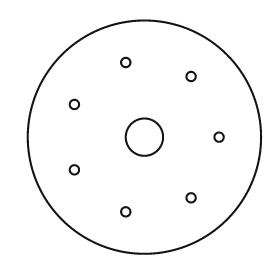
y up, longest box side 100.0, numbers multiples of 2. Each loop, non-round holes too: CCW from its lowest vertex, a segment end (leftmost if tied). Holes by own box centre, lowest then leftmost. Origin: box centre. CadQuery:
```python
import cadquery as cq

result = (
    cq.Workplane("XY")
    .moveTo(0.0, 0.0)
    .circle(50.0)
    .moveTo(-8.0, -32.0)
    .circle(2.0)
    .moveTo(20.0, -26.0)
    .circle(2.0)
    .moveTo(-30.0, -14.0)
    .circle(2.0)
    .moveTo(0.0, 0.0)
    .circle(8.0)
    .moveTo(32.0, 0.0)
    .circle(2.0)
    .moveTo(-30.0, 14.0)
    .circle(2.0)
    .moveTo(20.0, 26.0)
    .circle(2.0)
    .moveTo(-8.0, 32.0)
    .circle(2.0)
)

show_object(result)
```